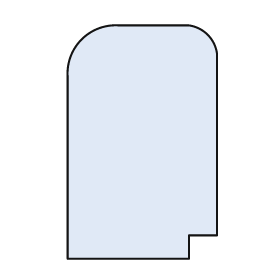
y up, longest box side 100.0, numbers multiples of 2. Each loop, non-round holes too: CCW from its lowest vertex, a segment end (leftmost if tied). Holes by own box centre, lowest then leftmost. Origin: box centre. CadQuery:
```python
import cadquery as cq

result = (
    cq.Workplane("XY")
    .moveTo(-32.0, -50.0)
    .lineTo(20.0, -50.0)
    .lineTo(20.0, -40.0)
    .lineTo(32.0, -40.0)
    .lineTo(32.0, 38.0)
    .threePointArc((28.0, 46.0), (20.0, 50.0))
    .lineTo(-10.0, 50.0)
    .threePointArc((-26.0, 44.0), (-32.0, 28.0))
    .close()
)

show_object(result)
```